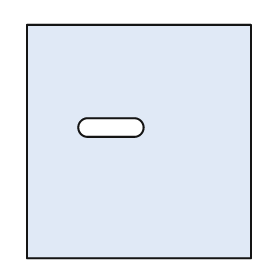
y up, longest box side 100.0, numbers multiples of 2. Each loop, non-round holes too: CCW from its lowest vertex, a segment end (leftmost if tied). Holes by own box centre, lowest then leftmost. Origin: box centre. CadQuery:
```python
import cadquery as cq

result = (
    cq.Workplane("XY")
    .moveTo(-48.0, -50.0)
    .lineTo(48.0, -50.0)
    .lineTo(48.0, 50.0)
    .lineTo(-48.0, 50.0)
    .close()
    .moveTo(-22.0, 2.0)
    .lineTo(-2.0, 2.0)
    .threePointArc((2.0, 6.0), (-2.0, 10.0))
    .lineTo(-22.0, 10.0)
    .threePointArc((-26.0, 6.0), (-22.0, 2.0))
    .close()
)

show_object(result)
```